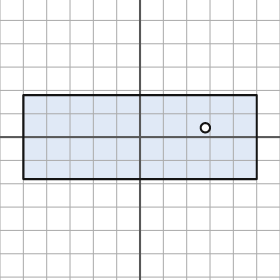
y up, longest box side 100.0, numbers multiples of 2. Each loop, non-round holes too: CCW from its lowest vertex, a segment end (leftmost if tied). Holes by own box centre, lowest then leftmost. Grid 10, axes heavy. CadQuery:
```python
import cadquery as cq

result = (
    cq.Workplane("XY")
    .moveTo(-50.0, -18.0)
    .lineTo(50.0, -18.0)
    .lineTo(50.0, 18.0)
    .lineTo(-50.0, 18.0)
    .close()
    .moveTo(28.0, 4.0)
    .circle(2.0)
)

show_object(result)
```